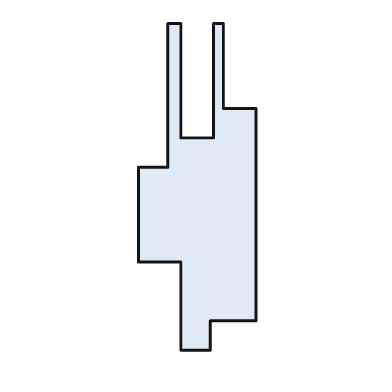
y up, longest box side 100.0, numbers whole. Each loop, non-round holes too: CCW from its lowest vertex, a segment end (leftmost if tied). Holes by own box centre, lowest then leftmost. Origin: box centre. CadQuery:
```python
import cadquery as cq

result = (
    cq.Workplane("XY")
    .moveTo(-5.0, -50.0)
    .lineTo(4.0, -50.0)
    .lineTo(4.0, -41.0)
    .lineTo(18.0, -41.0)
    .lineTo(18.0, 24.0)
    .lineTo(8.0, 24.0)
    .lineTo(8.0, 50.0)
    .lineTo(5.0, 50.0)
    .lineTo(5.0, 15.0)
    .lineTo(-5.0, 15.0)
    .lineTo(-5.0, 50.0)
    .lineTo(-9.0, 50.0)
    .lineTo(-9.0, 6.0)
    .lineTo(-18.0, 6.0)
    .lineTo(-18.0, -23.0)
    .lineTo(-5.0, -23.0)
    .close()
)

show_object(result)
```